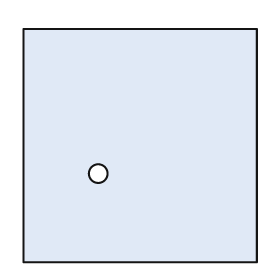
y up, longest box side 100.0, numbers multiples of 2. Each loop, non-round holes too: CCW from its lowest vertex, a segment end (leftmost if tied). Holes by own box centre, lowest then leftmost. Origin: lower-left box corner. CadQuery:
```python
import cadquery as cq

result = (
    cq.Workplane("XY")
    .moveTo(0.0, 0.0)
    .lineTo(100.0, 0.0)
    .lineTo(100.0, 100.0)
    .lineTo(0.0, 100.0)
    .close()
    .moveTo(32.0, 38.0)
    .circle(4.0)
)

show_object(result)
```